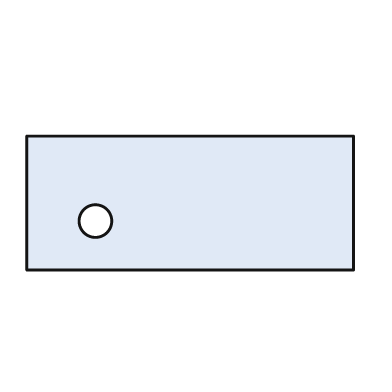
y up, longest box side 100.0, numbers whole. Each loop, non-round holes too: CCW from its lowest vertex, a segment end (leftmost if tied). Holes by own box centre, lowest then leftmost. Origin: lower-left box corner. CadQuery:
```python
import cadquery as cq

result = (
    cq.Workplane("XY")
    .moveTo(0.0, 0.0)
    .lineTo(100.0, 0.0)
    .lineTo(100.0, 41.0)
    .lineTo(0.0, 41.0)
    .close()
    .moveTo(21.0, 15.0)
    .circle(5.0)
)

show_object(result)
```